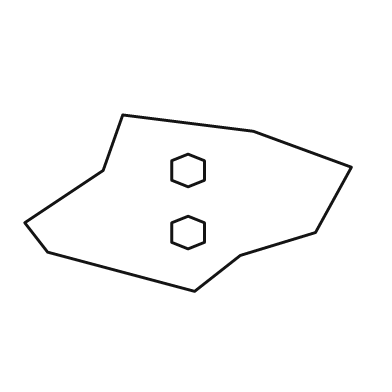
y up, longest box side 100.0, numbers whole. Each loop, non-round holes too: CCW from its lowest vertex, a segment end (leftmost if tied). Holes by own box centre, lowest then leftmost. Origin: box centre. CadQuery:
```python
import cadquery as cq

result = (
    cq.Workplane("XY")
    .moveTo(2.0, -27.0)
    .lineTo(16.0, -16.0)
    .lineTo(39.0, -9.0)
    .lineTo(50.0, 11.0)
    .lineTo(20.0, 22.0)
    .lineTo(-20.0, 27.0)
    .lineTo(-26.0, 10.0)
    .lineTo(-50.0, -6.0)
    .lineTo(-43.0, -15.0)
    .close()
    .moveTo(0.0, -14.0)
    .lineTo(5.0, -12.0)
    .lineTo(5.0, -6.0)
    .lineTo(0.0, -4.0)
    .lineTo(-5.0, -6.0)
    .lineTo(-5.0, -12.0)
    .close()
    .moveTo(0.0, 5.0)
    .lineTo(5.0, 7.0)
    .lineTo(5.0, 13.0)
    .lineTo(0.0, 15.0)
    .lineTo(-5.0, 13.0)
    .lineTo(-5.0, 7.0)
    .close()
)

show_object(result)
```